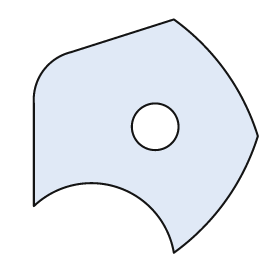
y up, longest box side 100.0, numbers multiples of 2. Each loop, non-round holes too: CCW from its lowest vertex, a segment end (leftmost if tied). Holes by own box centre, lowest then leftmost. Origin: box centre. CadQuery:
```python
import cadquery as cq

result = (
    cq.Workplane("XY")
    .moveTo(12.0, -50.0)
    .threePointArc((34.0, -28.0), (48.0, 0.0))
    .threePointArc((34.0, 28.0), (12.0, 50.0))
    .lineTo(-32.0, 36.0)
    .threePointArc((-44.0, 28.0), (-48.0, 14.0))
    .lineTo(-48.0, -30.0)
    .threePointArc((-12.0, -22.0), (12.0, -50.0))
    .close()
    .moveTo(4.0, 4.0)
    .circle(10.0)
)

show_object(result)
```